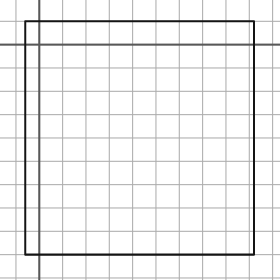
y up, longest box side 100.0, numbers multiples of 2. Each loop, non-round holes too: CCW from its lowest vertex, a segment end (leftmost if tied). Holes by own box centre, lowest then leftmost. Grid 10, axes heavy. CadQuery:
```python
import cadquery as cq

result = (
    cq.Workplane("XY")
    .moveTo(-6.0, -90.0)
    .lineTo(92.0, -90.0)
    .lineTo(92.0, 10.0)
    .lineTo(-6.0, 10.0)
    .close()
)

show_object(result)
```